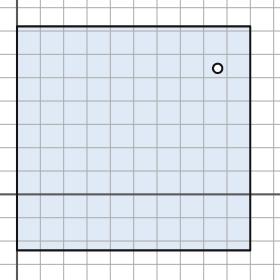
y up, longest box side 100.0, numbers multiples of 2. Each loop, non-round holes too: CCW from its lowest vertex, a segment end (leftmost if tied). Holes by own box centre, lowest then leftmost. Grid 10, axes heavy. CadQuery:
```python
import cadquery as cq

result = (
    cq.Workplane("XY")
    .moveTo(0.0, -24.0)
    .lineTo(100.0, -24.0)
    .lineTo(100.0, 72.0)
    .lineTo(0.0, 72.0)
    .close()
    .moveTo(86.0, 54.0)
    .circle(2.0)
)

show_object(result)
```